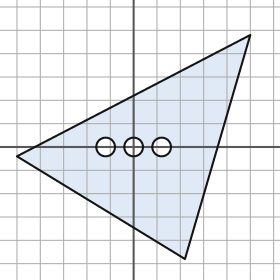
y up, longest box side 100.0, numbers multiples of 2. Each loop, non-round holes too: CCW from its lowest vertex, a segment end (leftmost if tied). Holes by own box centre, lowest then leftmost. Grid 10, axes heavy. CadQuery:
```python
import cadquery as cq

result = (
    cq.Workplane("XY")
    .moveTo(22.0, -48.0)
    .lineTo(50.0, 48.0)
    .lineTo(-50.0, -4.0)
    .close()
    .moveTo(-12.0, 0.0)
    .circle(4.0)
    .moveTo(0.0, 0.0)
    .circle(4.0)
    .moveTo(12.0, 0.0)
    .circle(4.0)
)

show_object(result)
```